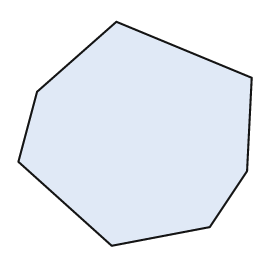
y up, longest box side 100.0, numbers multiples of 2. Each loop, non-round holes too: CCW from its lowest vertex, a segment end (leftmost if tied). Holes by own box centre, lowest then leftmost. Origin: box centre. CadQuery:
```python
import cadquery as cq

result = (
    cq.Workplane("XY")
    .moveTo(-10.0, -48.0)
    .lineTo(32.0, -40.0)
    .lineTo(48.0, -16.0)
    .lineTo(50.0, 24.0)
    .lineTo(-8.0, 48.0)
    .lineTo(-42.0, 18.0)
    .lineTo(-50.0, -12.0)
    .close()
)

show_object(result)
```